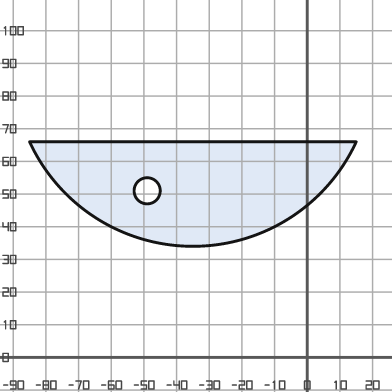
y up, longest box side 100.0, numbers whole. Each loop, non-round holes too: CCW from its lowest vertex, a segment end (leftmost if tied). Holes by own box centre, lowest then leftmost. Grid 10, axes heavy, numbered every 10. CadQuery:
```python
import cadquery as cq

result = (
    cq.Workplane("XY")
    .moveTo(-85.0, 66.0)
    .threePointArc((-35.0, 34.0), (15.0, 66.0))
    .close()
    .moveTo(-49.0, 51.0)
    .circle(4.0)
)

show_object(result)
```